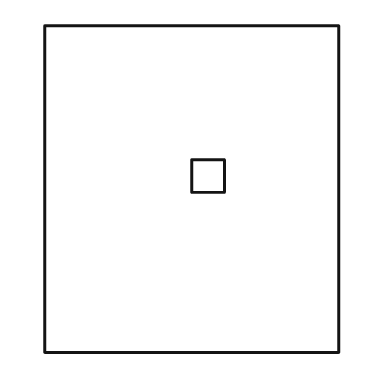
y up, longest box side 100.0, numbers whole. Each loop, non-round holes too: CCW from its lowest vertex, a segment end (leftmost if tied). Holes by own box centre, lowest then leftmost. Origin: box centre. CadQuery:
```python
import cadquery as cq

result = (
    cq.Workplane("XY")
    .moveTo(-45.0, -50.0)
    .lineTo(45.0, -50.0)
    .lineTo(45.0, 50.0)
    .lineTo(-45.0, 50.0)
    .close()
    .moveTo(0.0, -1.0)
    .lineTo(10.0, -1.0)
    .lineTo(10.0, 9.0)
    .lineTo(0.0, 9.0)
    .close()
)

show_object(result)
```